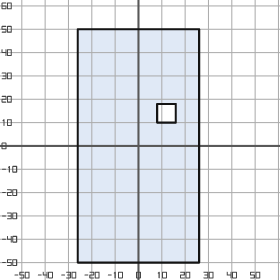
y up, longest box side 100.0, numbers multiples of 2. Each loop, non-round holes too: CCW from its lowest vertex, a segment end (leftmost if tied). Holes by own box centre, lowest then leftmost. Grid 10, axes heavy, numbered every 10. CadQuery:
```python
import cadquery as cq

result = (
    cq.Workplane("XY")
    .moveTo(-26.0, -50.0)
    .lineTo(26.0, -50.0)
    .lineTo(26.0, 50.0)
    .lineTo(-26.0, 50.0)
    .close()
    .moveTo(8.0, 10.0)
    .lineTo(16.0, 10.0)
    .lineTo(16.0, 18.0)
    .lineTo(8.0, 18.0)
    .close()
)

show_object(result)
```